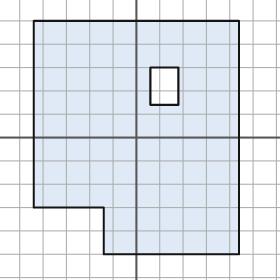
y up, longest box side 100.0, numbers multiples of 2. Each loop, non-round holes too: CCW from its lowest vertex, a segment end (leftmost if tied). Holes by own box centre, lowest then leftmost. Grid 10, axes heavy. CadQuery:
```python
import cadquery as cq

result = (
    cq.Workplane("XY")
    .moveTo(-14.0, -50.0)
    .lineTo(44.0, -50.0)
    .lineTo(44.0, 50.0)
    .lineTo(-44.0, 50.0)
    .lineTo(-44.0, -30.0)
    .lineTo(-14.0, -30.0)
    .close()
    .moveTo(6.0, 14.0)
    .lineTo(18.0, 14.0)
    .lineTo(18.0, 30.0)
    .lineTo(6.0, 30.0)
    .close()
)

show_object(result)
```